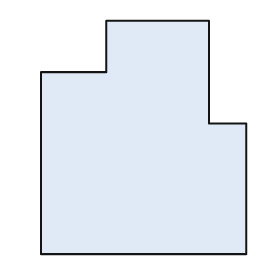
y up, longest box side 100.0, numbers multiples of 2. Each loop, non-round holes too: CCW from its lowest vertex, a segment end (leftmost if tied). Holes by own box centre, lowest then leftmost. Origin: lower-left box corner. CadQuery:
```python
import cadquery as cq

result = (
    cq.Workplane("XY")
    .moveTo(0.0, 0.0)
    .lineTo(88.0, 0.0)
    .lineTo(88.0, 56.0)
    .lineTo(72.0, 56.0)
    .lineTo(72.0, 100.0)
    .lineTo(28.0, 100.0)
    .lineTo(28.0, 78.0)
    .lineTo(0.0, 78.0)
    .close()
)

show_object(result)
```